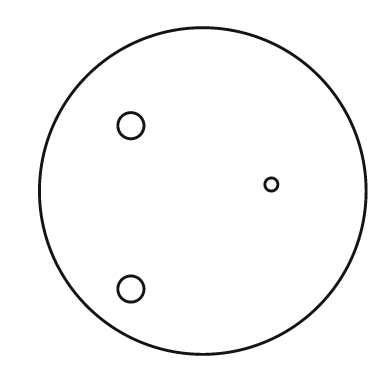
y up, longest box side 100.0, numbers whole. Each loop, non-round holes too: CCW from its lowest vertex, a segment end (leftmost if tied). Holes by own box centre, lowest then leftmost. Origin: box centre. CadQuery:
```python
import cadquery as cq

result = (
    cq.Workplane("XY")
    .moveTo(0.0, 0.0)
    .circle(50.0)
    .moveTo(-22.0, -30.0)
    .circle(4.0)
    .moveTo(21.0, 2.0)
    .circle(2.0)
    .moveTo(-22.0, 20.0)
    .circle(4.0)
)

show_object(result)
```